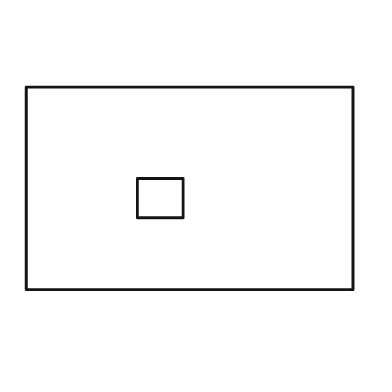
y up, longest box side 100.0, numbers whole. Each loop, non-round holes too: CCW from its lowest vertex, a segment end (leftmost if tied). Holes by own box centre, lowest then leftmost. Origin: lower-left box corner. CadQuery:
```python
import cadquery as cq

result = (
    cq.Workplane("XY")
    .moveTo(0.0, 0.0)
    .lineTo(100.0, 0.0)
    .lineTo(100.0, 62.0)
    .lineTo(0.0, 62.0)
    .close()
    .moveTo(34.0, 22.0)
    .lineTo(48.0, 22.0)
    .lineTo(48.0, 34.0)
    .lineTo(34.0, 34.0)
    .close()
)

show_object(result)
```